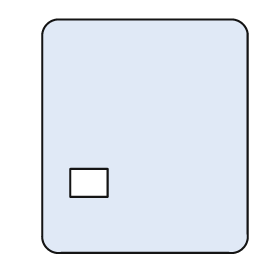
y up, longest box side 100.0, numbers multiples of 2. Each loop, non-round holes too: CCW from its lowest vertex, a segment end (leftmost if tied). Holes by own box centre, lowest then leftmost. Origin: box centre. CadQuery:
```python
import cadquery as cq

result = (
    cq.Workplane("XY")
    .moveTo(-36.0, -50.0)
    .lineTo(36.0, -50.0)
    .threePointArc((42.0, -48.0), (44.0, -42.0))
    .lineTo(44.0, 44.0)
    .threePointArc((42.0, 48.0), (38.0, 50.0))
    .lineTo(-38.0, 50.0)
    .threePointArc((-42.0, 48.0), (-44.0, 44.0))
    .lineTo(-44.0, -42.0)
    .threePointArc((-42.0, -48.0), (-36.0, -50.0))
    .close()
    .moveTo(-32.0, -26.0)
    .lineTo(-16.0, -26.0)
    .lineTo(-16.0, -14.0)
    .lineTo(-32.0, -14.0)
    .close()
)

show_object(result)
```